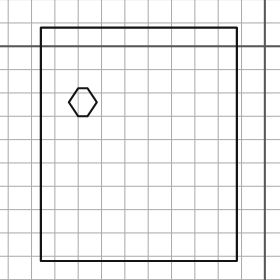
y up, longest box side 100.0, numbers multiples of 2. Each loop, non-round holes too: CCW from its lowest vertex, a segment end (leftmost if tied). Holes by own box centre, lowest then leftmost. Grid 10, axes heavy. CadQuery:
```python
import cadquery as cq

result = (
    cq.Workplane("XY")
    .moveTo(-96.0, -92.0)
    .lineTo(-12.0, -92.0)
    .lineTo(-12.0, 8.0)
    .lineTo(-96.0, 8.0)
    .close()
    .moveTo(-80.0, -30.0)
    .lineTo(-76.0, -30.0)
    .lineTo(-72.0, -24.0)
    .lineTo(-76.0, -18.0)
    .lineTo(-80.0, -18.0)
    .lineTo(-84.0, -24.0)
    .close()
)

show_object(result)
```